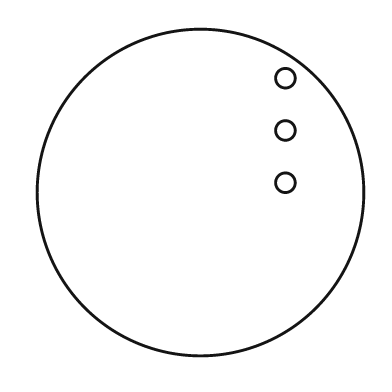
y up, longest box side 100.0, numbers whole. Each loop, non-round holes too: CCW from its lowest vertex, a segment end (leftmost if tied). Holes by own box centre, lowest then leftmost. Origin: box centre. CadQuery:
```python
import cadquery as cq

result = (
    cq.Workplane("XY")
    .moveTo(0.0, 0.0)
    .circle(50.0)
    .moveTo(26.0, 3.0)
    .circle(3.0)
    .moveTo(26.0, 19.0)
    .circle(3.0)
    .moveTo(26.0, 35.0)
    .circle(3.0)
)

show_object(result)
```